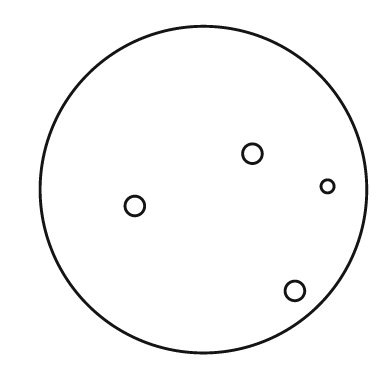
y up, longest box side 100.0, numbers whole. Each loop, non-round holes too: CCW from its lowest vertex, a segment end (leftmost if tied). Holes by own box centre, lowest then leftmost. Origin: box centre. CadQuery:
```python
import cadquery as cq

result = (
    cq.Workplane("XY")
    .moveTo(0.0, 0.0)
    .circle(50.0)
    .moveTo(28.0, -31.0)
    .circle(3.0)
    .moveTo(-21.0, -5.0)
    .circle(3.0)
    .moveTo(38.0, 1.0)
    .circle(2.0)
    .moveTo(15.0, 11.0)
    .circle(3.0)
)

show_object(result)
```